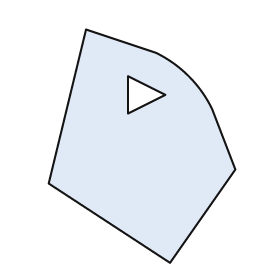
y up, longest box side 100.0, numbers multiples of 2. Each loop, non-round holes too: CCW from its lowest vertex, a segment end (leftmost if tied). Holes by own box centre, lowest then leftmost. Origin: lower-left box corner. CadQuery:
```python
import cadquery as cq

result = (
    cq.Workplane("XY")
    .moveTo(52.0, 0.0)
    .lineTo(80.0, 40.0)
    .lineTo(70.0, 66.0)
    .threePointArc((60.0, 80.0), (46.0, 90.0))
    .lineTo(16.0, 100.0)
    .lineTo(0.0, 34.0)
    .close()
    .moveTo(34.0, 64.0)
    .lineTo(50.0, 72.0)
    .lineTo(34.0, 80.0)
    .close()
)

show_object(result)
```